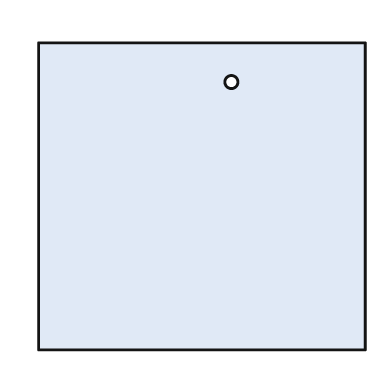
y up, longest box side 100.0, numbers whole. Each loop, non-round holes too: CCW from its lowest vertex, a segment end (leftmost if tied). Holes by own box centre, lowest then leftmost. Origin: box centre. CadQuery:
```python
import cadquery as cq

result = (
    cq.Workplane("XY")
    .moveTo(-50.0, -47.0)
    .lineTo(50.0, -47.0)
    .lineTo(50.0, 47.0)
    .lineTo(-50.0, 47.0)
    .close()
    .moveTo(9.0, 35.0)
    .circle(2.0)
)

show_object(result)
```